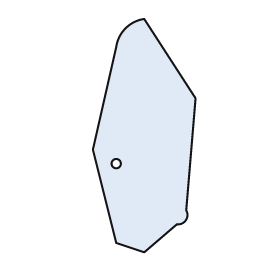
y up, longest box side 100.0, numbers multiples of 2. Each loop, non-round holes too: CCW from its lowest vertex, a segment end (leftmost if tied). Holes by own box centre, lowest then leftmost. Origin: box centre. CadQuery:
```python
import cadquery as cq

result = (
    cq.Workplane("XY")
    .moveTo(0.0, -50.0)
    .lineTo(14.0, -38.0)
    .threePointArc((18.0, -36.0), (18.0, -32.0))
    .lineTo(22.0, 16.0)
    .lineTo(0.0, 50.0)
    .threePointArc((-8.0, 46.0), (-12.0, 38.0))
    .lineTo(-22.0, -6.0)
    .lineTo(-12.0, -46.0)
    .close()
    .moveTo(-12.0, -12.0)
    .circle(2.0)
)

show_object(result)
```